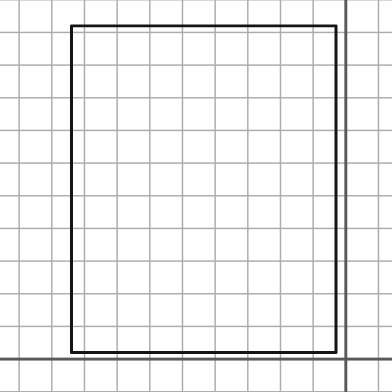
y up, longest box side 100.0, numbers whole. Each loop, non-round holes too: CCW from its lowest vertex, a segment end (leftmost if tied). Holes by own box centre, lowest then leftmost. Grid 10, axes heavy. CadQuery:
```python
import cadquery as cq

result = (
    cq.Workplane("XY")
    .moveTo(-84.0, 2.0)
    .lineTo(-3.0, 2.0)
    .lineTo(-3.0, 102.0)
    .lineTo(-84.0, 102.0)
    .close()
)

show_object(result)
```